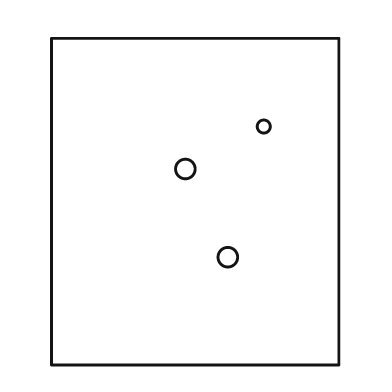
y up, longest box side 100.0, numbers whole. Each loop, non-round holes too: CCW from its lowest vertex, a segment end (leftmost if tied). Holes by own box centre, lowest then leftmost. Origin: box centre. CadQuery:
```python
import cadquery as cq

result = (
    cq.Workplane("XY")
    .moveTo(-44.0, -50.0)
    .lineTo(44.0, -50.0)
    .lineTo(44.0, 50.0)
    .lineTo(-44.0, 50.0)
    .close()
    .moveTo(10.0, -17.0)
    .circle(3.0)
    .moveTo(-3.0, 10.0)
    .circle(3.0)
    .moveTo(21.0, 23.0)
    .circle(2.0)
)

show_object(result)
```